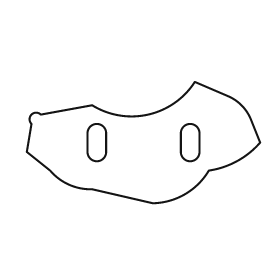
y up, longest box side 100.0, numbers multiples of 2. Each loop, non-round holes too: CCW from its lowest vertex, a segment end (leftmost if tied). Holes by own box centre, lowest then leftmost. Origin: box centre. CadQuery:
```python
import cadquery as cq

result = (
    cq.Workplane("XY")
    .moveTo(4.0, -26.0)
    .threePointArc((18.0, -22.0), (28.0, -12.0))
    .threePointArc((40.0, -8.0), (50.0, 0.0))
    .lineTo(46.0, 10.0)
    .threePointArc((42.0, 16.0), (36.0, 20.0))
    .lineTo(22.0, 26.0)
    .threePointArc((2.0, 12.0), (-22.0, 16.0))
    .lineTo(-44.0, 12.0)
    .threePointArc((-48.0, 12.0), (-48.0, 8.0))
    .lineTo(-50.0, -4.0)
    .lineTo(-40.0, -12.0)
    .threePointArc((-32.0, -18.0), (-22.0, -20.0))
    .close()
    .moveTo(-24.0, -4.0)
    .threePointArc((-20.0, -8.0), (-16.0, -4.0))
    .lineTo(-16.0, 4.0)
    .threePointArc((-20.0, 8.0), (-24.0, 4.0))
    .close()
    .moveTo(16.0, -4.0)
    .threePointArc((20.0, -8.0), (24.0, -4.0))
    .lineTo(24.0, 4.0)
    .threePointArc((20.0, 8.0), (16.0, 4.0))
    .close()
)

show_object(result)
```